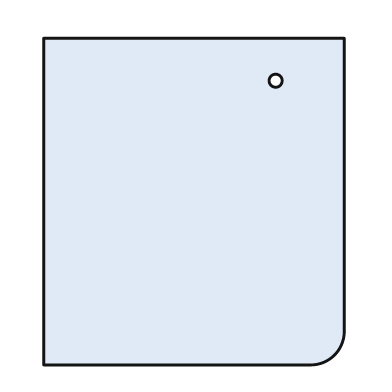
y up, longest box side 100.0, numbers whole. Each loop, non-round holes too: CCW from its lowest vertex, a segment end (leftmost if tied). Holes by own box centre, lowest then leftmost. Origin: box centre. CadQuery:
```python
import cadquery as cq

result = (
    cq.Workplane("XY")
    .moveTo(-46.0, -50.0)
    .lineTo(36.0, -50.0)
    .threePointArc((43.0, -47.0), (46.0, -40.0))
    .lineTo(46.0, 50.0)
    .lineTo(-46.0, 50.0)
    .close()
    .moveTo(25.0, 37.0)
    .circle(2.0)
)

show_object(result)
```